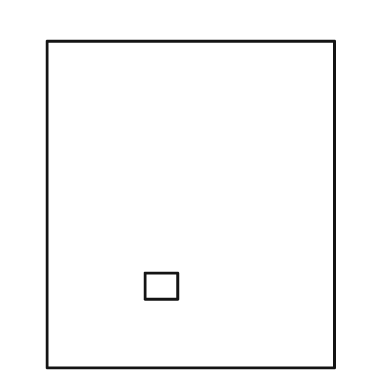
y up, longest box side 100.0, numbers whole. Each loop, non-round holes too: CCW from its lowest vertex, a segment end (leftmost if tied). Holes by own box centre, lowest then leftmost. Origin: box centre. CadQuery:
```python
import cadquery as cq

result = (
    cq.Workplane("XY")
    .moveTo(-44.0, -50.0)
    .lineTo(44.0, -50.0)
    .lineTo(44.0, 50.0)
    .lineTo(-44.0, 50.0)
    .close()
    .moveTo(-14.0, -29.0)
    .lineTo(-4.0, -29.0)
    .lineTo(-4.0, -21.0)
    .lineTo(-14.0, -21.0)
    .close()
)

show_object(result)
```